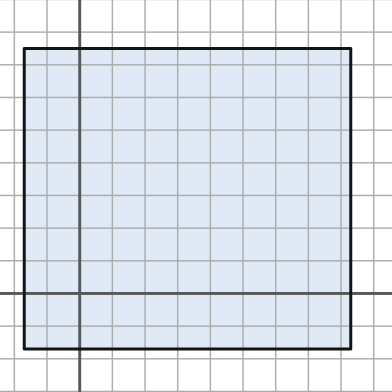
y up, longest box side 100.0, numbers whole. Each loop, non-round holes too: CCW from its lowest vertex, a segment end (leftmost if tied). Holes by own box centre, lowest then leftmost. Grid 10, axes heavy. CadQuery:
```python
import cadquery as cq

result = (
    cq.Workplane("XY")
    .moveTo(-17.0, -17.0)
    .lineTo(83.0, -17.0)
    .lineTo(83.0, 75.0)
    .lineTo(-17.0, 75.0)
    .close()
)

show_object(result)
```